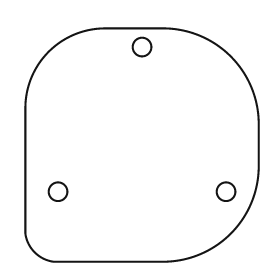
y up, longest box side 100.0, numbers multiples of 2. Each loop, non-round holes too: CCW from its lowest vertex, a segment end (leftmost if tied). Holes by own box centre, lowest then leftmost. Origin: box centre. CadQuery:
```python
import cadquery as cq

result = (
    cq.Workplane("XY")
    .moveTo(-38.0, -50.0)
    .lineTo(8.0, -50.0)
    .threePointArc((38.0, -38.0), (50.0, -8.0))
    .lineTo(50.0, 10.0)
    .threePointArc((38.0, 38.0), (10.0, 50.0))
    .lineTo(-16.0, 50.0)
    .threePointArc((-40.0, 40.0), (-50.0, 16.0))
    .lineTo(-50.0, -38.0)
    .threePointArc((-46.0, -46.0), (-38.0, -50.0))
    .close()
    .moveTo(-36.0, -20.0)
    .circle(4.0)
    .moveTo(36.0, -20.0)
    .circle(4.0)
    .moveTo(0.0, 42.0)
    .circle(4.0)
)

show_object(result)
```